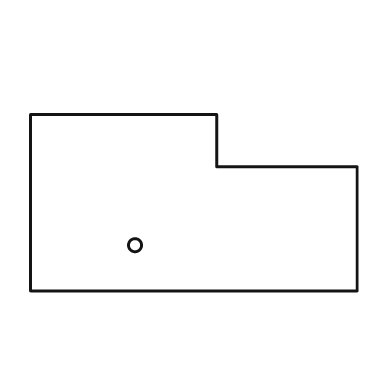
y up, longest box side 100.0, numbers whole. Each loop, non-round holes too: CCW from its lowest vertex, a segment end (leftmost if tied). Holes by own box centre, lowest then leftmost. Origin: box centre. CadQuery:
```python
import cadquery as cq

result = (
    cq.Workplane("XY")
    .moveTo(-50.0, -27.0)
    .lineTo(50.0, -27.0)
    .lineTo(50.0, 11.0)
    .lineTo(7.0, 11.0)
    .lineTo(7.0, 27.0)
    .lineTo(-50.0, 27.0)
    .close()
    .moveTo(-18.0, -13.0)
    .circle(2.0)
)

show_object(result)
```